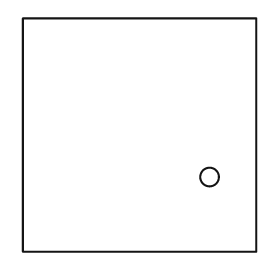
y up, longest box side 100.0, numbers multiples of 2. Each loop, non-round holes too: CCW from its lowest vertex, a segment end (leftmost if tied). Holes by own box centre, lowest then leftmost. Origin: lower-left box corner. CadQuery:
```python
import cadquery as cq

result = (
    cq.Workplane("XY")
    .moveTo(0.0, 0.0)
    .lineTo(100.0, 0.0)
    .lineTo(100.0, 100.0)
    .lineTo(0.0, 100.0)
    .close()
    .moveTo(80.0, 32.0)
    .circle(4.0)
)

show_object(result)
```